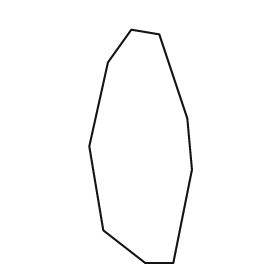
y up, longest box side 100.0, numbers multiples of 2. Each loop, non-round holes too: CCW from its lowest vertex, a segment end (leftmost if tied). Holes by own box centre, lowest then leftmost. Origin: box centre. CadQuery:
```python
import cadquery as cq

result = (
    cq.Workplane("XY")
    .moveTo(2.0, -50.0)
    .lineTo(14.0, -50.0)
    .lineTo(22.0, -10.0)
    .lineTo(20.0, 12.0)
    .lineTo(8.0, 48.0)
    .lineTo(-4.0, 50.0)
    .lineTo(-14.0, 36.0)
    .lineTo(-22.0, 0.0)
    .lineTo(-16.0, -36.0)
    .close()
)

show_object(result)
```